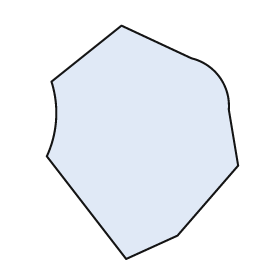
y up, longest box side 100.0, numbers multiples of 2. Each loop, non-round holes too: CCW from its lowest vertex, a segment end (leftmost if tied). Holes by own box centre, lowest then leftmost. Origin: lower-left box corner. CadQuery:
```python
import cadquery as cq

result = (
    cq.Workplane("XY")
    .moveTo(34.0, 0.0)
    .lineTo(56.0, 10.0)
    .lineTo(82.0, 40.0)
    .lineTo(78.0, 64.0)
    .threePointArc((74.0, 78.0), (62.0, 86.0))
    .lineTo(32.0, 100.0)
    .lineTo(2.0, 76.0)
    .threePointArc((4.0, 60.0), (0.0, 44.0))
    .close()
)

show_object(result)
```